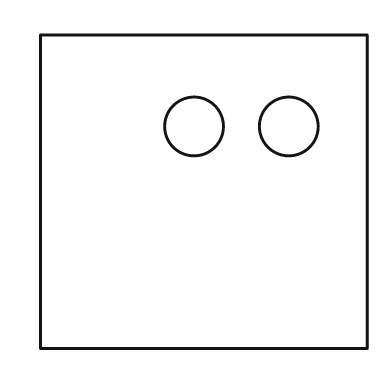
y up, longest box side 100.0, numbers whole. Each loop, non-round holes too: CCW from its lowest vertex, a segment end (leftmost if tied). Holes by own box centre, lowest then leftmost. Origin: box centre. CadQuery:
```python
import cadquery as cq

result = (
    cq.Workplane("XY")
    .moveTo(-50.0, -48.0)
    .lineTo(50.0, -48.0)
    .lineTo(50.0, 48.0)
    .lineTo(-50.0, 48.0)
    .close()
    .moveTo(-3.0, 20.0)
    .circle(9.0)
    .moveTo(26.0, 20.0)
    .circle(9.0)
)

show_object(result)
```